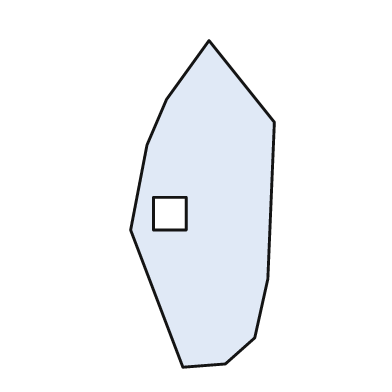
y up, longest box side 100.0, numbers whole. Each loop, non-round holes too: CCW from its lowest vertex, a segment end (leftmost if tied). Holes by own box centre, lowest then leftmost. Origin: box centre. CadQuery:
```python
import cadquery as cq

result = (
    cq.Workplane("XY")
    .moveTo(-6.0, -50.0)
    .lineTo(7.0, -49.0)
    .lineTo(16.0, -41.0)
    .lineTo(20.0, -23.0)
    .lineTo(22.0, 25.0)
    .lineTo(2.0, 50.0)
    .lineTo(-11.0, 32.0)
    .lineTo(-17.0, 18.0)
    .lineTo(-22.0, -8.0)
    .close()
    .moveTo(-15.0, -8.0)
    .lineTo(-5.0, -8.0)
    .lineTo(-5.0, 2.0)
    .lineTo(-15.0, 2.0)
    .close()
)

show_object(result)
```